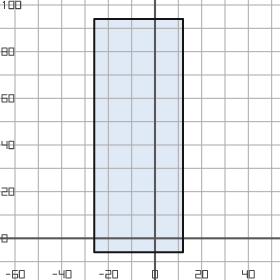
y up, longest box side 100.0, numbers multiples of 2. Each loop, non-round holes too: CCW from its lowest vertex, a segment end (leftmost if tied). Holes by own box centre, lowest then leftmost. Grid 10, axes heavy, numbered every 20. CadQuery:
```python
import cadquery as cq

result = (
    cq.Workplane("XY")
    .moveTo(-26.0, -6.0)
    .lineTo(12.0, -6.0)
    .lineTo(12.0, 94.0)
    .lineTo(-26.0, 94.0)
    .close()
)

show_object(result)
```